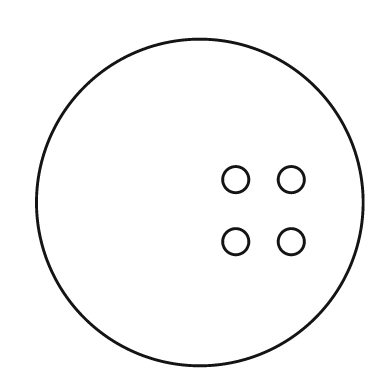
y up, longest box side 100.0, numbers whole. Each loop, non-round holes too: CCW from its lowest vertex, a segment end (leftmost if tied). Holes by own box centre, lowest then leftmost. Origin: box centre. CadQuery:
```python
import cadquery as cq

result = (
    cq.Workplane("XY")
    .moveTo(0.0, 0.0)
    .circle(50.0)
    .moveTo(11.0, -12.0)
    .circle(4.0)
    .moveTo(28.0, -12.0)
    .circle(4.0)
    .moveTo(11.0, 7.0)
    .circle(4.0)
    .moveTo(28.0, 7.0)
    .circle(4.0)
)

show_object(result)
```